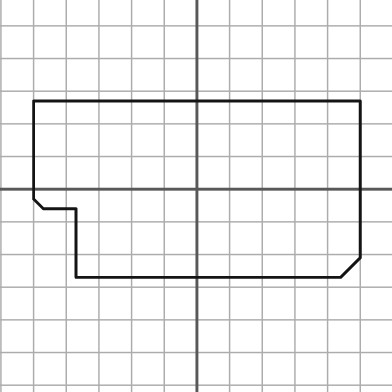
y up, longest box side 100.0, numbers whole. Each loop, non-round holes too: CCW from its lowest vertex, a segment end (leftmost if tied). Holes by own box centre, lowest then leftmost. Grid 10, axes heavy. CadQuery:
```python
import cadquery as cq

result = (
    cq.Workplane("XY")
    .moveTo(-37.0, -27.0)
    .lineTo(44.0, -27.0)
    .lineTo(50.0, -21.0)
    .lineTo(50.0, 27.0)
    .lineTo(-50.0, 27.0)
    .lineTo(-50.0, -3.0)
    .lineTo(-47.0, -6.0)
    .lineTo(-37.0, -6.0)
    .close()
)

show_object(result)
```